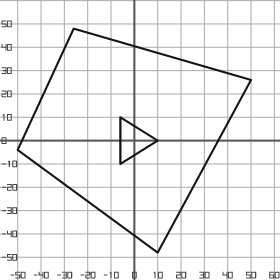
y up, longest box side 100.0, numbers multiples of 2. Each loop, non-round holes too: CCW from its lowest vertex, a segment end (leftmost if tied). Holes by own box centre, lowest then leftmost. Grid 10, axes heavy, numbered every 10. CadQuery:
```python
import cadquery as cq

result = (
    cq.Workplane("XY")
    .moveTo(10.0, -48.0)
    .lineTo(50.0, 26.0)
    .lineTo(-26.0, 48.0)
    .lineTo(-50.0, -4.0)
    .close()
    .moveTo(-6.0, -10.0)
    .lineTo(10.0, 0.0)
    .lineTo(-6.0, 10.0)
    .close()
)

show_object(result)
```